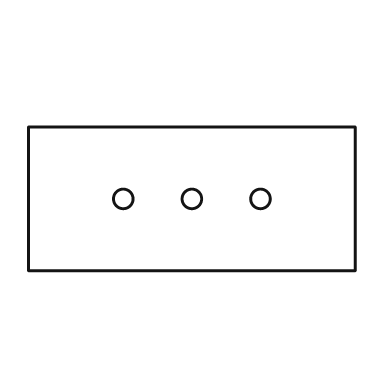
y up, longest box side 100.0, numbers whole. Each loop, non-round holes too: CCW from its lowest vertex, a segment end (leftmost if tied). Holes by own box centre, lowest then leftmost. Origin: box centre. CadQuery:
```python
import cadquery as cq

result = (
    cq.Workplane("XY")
    .moveTo(-50.0, -22.0)
    .lineTo(50.0, -22.0)
    .lineTo(50.0, 22.0)
    .lineTo(-50.0, 22.0)
    .close()
    .moveTo(-21.0, 0.0)
    .circle(3.0)
    .moveTo(0.0, 0.0)
    .circle(3.0)
    .moveTo(21.0, 0.0)
    .circle(3.0)
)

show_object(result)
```